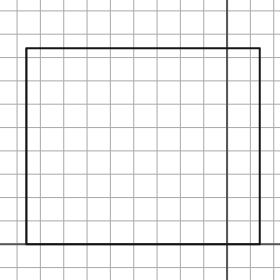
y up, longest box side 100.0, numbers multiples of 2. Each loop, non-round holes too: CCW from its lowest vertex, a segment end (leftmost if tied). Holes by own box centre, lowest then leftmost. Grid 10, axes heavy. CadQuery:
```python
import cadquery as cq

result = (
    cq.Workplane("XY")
    .moveTo(-86.0, 0.0)
    .lineTo(14.0, 0.0)
    .lineTo(14.0, 84.0)
    .lineTo(-86.0, 84.0)
    .close()
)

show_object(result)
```